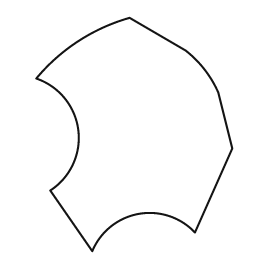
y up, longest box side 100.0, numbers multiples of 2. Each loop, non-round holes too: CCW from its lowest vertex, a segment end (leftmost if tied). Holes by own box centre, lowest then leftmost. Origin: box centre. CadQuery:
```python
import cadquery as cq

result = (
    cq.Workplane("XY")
    .moveTo(-18.0, -50.0)
    .threePointArc((2.0, -34.0), (26.0, -42.0))
    .lineTo(42.0, -6.0)
    .lineTo(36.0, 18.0)
    .threePointArc((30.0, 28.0), (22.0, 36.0))
    .lineTo(-2.0, 50.0)
    .threePointArc((-24.0, 40.0), (-42.0, 24.0))
    .threePointArc((-24.0, 2.0), (-36.0, -24.0))
    .close()
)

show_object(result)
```